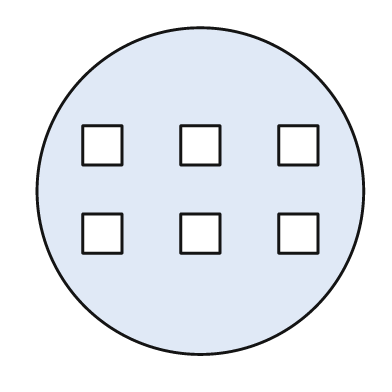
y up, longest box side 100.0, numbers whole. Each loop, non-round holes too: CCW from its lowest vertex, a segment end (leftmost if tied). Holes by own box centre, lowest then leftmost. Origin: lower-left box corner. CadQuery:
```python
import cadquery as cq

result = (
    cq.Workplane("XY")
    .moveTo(50.0, 50.0)
    .circle(50.0)
    .moveTo(14.0, 31.0)
    .lineTo(26.0, 31.0)
    .lineTo(26.0, 43.0)
    .lineTo(14.0, 43.0)
    .close()
    .moveTo(44.0, 31.0)
    .lineTo(56.0, 31.0)
    .lineTo(56.0, 43.0)
    .lineTo(44.0, 43.0)
    .close()
    .moveTo(74.0, 31.0)
    .lineTo(86.0, 31.0)
    .lineTo(86.0, 43.0)
    .lineTo(74.0, 43.0)
    .close()
    .moveTo(14.0, 58.0)
    .lineTo(26.0, 58.0)
    .lineTo(26.0, 70.0)
    .lineTo(14.0, 70.0)
    .close()
    .moveTo(44.0, 58.0)
    .lineTo(56.0, 58.0)
    .lineTo(56.0, 70.0)
    .lineTo(44.0, 70.0)
    .close()
    .moveTo(74.0, 58.0)
    .lineTo(86.0, 58.0)
    .lineTo(86.0, 70.0)
    .lineTo(74.0, 70.0)
    .close()
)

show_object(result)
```